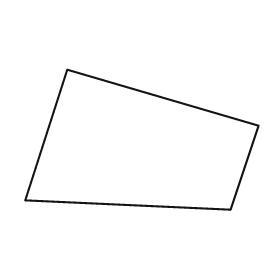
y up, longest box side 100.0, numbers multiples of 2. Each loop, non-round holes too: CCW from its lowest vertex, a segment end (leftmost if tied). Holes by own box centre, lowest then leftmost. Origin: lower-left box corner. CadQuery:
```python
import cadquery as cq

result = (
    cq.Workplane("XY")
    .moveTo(88.0, 0.0)
    .lineTo(100.0, 36.0)
    .lineTo(18.0, 60.0)
    .lineTo(0.0, 4.0)
    .close()
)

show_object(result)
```